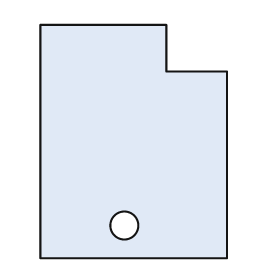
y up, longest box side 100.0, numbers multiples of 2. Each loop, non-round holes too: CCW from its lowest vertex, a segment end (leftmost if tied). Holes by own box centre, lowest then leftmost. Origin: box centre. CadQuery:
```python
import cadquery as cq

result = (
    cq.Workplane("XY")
    .moveTo(-40.0, -50.0)
    .lineTo(40.0, -50.0)
    .lineTo(40.0, 30.0)
    .lineTo(14.0, 30.0)
    .lineTo(14.0, 50.0)
    .lineTo(-40.0, 50.0)
    .close()
    .moveTo(-4.0, -36.0)
    .circle(6.0)
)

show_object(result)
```